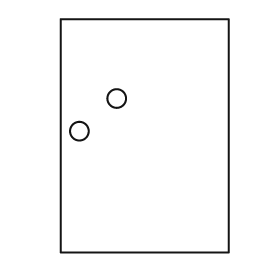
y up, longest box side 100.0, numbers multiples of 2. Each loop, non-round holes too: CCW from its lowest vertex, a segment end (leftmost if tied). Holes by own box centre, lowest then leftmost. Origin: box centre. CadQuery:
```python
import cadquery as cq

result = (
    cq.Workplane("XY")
    .moveTo(-36.0, -50.0)
    .lineTo(36.0, -50.0)
    .lineTo(36.0, 50.0)
    .lineTo(-36.0, 50.0)
    .close()
    .moveTo(-28.0, 2.0)
    .circle(4.0)
    .moveTo(-12.0, 16.0)
    .circle(4.0)
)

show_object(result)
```